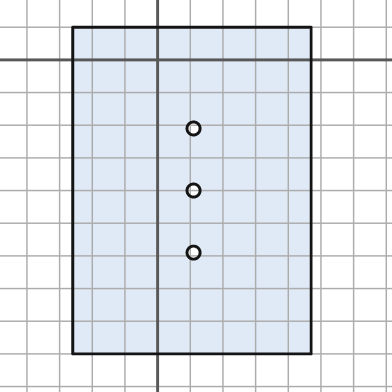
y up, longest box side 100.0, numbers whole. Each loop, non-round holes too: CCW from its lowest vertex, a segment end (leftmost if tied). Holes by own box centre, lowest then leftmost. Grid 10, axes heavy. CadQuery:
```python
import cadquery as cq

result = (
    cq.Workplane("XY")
    .moveTo(-26.0, -90.0)
    .lineTo(47.0, -90.0)
    .lineTo(47.0, 10.0)
    .lineTo(-26.0, 10.0)
    .close()
    .moveTo(11.0, -59.0)
    .circle(2.0)
    .moveTo(11.0, -40.0)
    .circle(2.0)
    .moveTo(11.0, -21.0)
    .circle(2.0)
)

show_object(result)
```